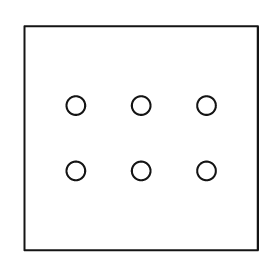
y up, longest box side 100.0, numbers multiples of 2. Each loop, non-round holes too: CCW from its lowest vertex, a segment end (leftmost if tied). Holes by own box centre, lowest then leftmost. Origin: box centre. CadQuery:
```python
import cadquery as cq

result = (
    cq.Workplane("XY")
    .moveTo(-50.0, -48.0)
    .lineTo(50.0, -48.0)
    .lineTo(50.0, 48.0)
    .lineTo(-50.0, 48.0)
    .close()
    .moveTo(-28.0, -14.0)
    .circle(4.0)
    .moveTo(0.0, -14.0)
    .circle(4.0)
    .moveTo(28.0, -14.0)
    .circle(4.0)
    .moveTo(-28.0, 14.0)
    .circle(4.0)
    .moveTo(0.0, 14.0)
    .circle(4.0)
    .moveTo(28.0, 14.0)
    .circle(4.0)
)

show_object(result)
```